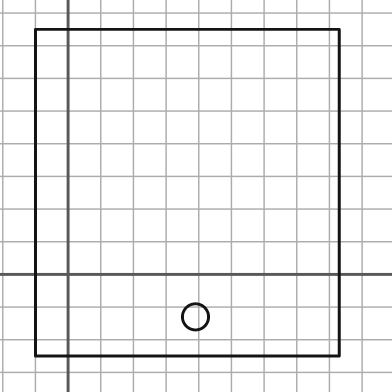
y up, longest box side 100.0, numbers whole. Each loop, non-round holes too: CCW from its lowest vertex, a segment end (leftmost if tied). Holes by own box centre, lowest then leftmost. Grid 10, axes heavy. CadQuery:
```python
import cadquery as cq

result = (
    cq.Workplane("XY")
    .moveTo(-10.0, -25.0)
    .lineTo(83.0, -25.0)
    .lineTo(83.0, 75.0)
    .lineTo(-10.0, 75.0)
    .close()
    .moveTo(39.0, -13.0)
    .circle(4.0)
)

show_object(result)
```